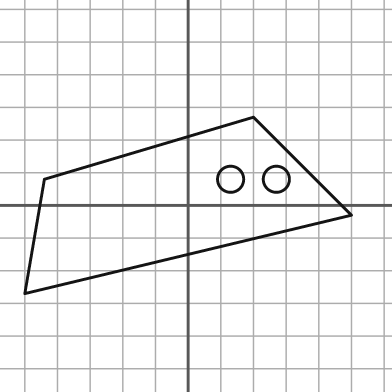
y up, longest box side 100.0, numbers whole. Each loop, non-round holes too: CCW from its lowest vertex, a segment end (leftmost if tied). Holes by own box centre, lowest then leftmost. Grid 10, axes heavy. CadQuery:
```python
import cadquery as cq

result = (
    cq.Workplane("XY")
    .moveTo(-50.0, -27.0)
    .lineTo(50.0, -3.0)
    .lineTo(20.0, 27.0)
    .lineTo(-44.0, 8.0)
    .close()
    .moveTo(13.0, 8.0)
    .circle(4.0)
    .moveTo(27.0, 8.0)
    .circle(4.0)
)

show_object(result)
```